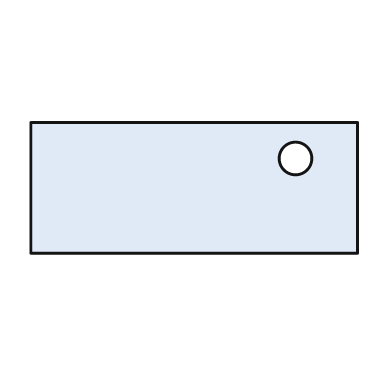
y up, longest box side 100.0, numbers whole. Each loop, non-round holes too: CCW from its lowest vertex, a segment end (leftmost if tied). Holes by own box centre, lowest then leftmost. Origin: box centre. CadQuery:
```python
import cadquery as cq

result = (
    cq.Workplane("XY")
    .moveTo(-50.0, -20.0)
    .lineTo(50.0, -20.0)
    .lineTo(50.0, 20.0)
    .lineTo(-50.0, 20.0)
    .close()
    .moveTo(31.0, 9.0)
    .circle(5.0)
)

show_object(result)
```